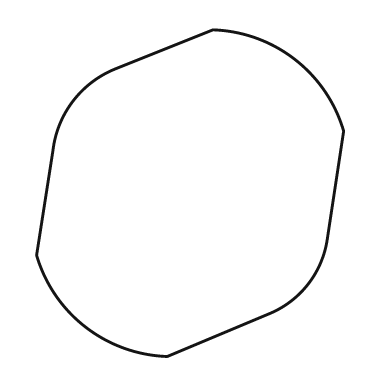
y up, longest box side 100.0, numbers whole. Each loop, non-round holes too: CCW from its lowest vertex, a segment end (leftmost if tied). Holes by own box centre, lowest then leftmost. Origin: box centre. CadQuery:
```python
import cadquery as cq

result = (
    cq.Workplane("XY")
    .moveTo(-7.0, -50.0)
    .lineTo(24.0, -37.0)
    .threePointArc((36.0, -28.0), (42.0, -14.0))
    .lineTo(47.0, 19.0)
    .threePointArc((32.0, 41.0), (7.0, 50.0))
    .lineTo(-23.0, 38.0)
    .threePointArc((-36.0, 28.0), (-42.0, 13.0))
    .lineTo(-47.0, -19.0)
    .threePointArc((-32.0, -41.0), (-7.0, -50.0))
    .close()
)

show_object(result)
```